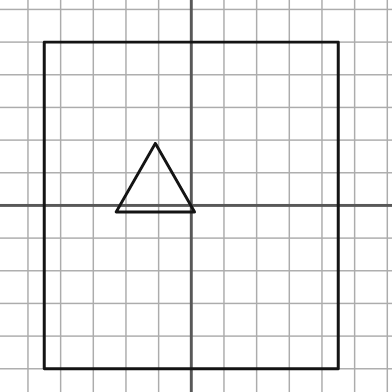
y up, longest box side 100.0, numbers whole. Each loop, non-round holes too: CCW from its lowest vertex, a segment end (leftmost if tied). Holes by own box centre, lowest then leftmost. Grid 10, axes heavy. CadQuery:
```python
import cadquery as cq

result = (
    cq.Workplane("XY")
    .moveTo(-45.0, -50.0)
    .lineTo(45.0, -50.0)
    .lineTo(45.0, 50.0)
    .lineTo(-45.0, 50.0)
    .close()
    .moveTo(-23.0, -2.0)
    .lineTo(1.0, -2.0)
    .lineTo(-11.0, 19.0)
    .close()
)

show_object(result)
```